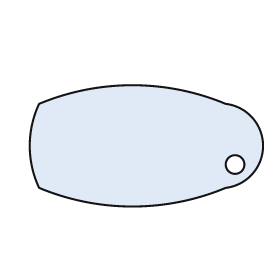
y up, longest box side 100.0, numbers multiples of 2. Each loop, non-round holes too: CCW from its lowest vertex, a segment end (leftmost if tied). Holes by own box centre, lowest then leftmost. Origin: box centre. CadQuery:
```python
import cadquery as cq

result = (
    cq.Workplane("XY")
    .moveTo(-46.0, -18.0)
    .threePointArc((-6.0, -26.0), (34.0, -18.0))
    .threePointArc((50.0, 0.0), (34.0, 18.0))
    .threePointArc((-6.0, 26.0), (-46.0, 18.0))
    .threePointArc((-50.0, 0.0), (-46.0, -18.0))
    .close()
    .moveTo(38.0, -8.0)
    .circle(4.0)
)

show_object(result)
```